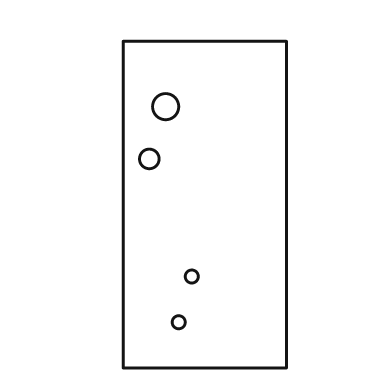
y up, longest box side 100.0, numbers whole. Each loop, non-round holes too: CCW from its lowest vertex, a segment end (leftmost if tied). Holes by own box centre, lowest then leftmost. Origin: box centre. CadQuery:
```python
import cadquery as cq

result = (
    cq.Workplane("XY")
    .moveTo(-25.0, -50.0)
    .lineTo(25.0, -50.0)
    .lineTo(25.0, 50.0)
    .lineTo(-25.0, 50.0)
    .close()
    .moveTo(-8.0, -36.0)
    .circle(2.0)
    .moveTo(-4.0, -22.0)
    .circle(2.0)
    .moveTo(-17.0, 14.0)
    .circle(3.0)
    .moveTo(-12.0, 30.0)
    .circle(4.0)
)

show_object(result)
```